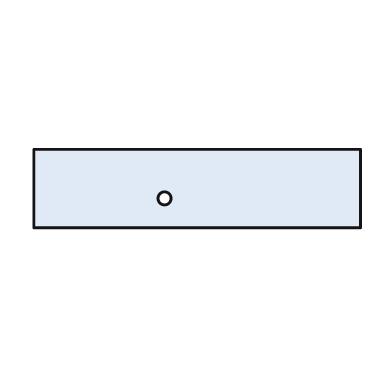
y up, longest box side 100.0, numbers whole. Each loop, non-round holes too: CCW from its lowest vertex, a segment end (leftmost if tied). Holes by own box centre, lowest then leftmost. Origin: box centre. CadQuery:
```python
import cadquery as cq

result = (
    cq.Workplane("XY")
    .moveTo(-50.0, -12.0)
    .lineTo(50.0, -12.0)
    .lineTo(50.0, 12.0)
    .lineTo(-50.0, 12.0)
    .close()
    .moveTo(-10.0, -3.0)
    .circle(2.0)
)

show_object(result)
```